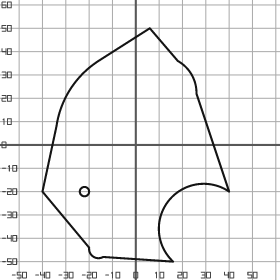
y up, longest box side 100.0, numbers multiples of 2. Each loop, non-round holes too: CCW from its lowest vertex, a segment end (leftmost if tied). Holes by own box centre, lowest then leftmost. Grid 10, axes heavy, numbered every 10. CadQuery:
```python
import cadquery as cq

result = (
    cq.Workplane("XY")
    .moveTo(16.0, -50.0)
    .threePointArc((14.0, -24.0), (40.0, -20.0))
    .lineTo(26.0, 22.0)
    .threePointArc((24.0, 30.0), (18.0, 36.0))
    .lineTo(6.0, 50.0)
    .lineTo(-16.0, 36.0)
    .threePointArc((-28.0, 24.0), (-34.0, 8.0))
    .lineTo(-40.0, -20.0)
    .lineTo(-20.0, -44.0)
    .threePointArc((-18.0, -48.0), (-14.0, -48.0))
    .close()
    .moveTo(-22.0, -20.0)
    .circle(2.0)
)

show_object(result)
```